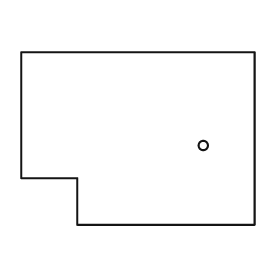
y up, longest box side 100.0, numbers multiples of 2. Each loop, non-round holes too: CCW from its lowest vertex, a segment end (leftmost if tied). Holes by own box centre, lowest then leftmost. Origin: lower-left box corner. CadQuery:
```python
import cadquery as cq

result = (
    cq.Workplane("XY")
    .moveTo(24.0, 0.0)
    .lineTo(100.0, 0.0)
    .lineTo(100.0, 74.0)
    .lineTo(0.0, 74.0)
    .lineTo(0.0, 20.0)
    .lineTo(24.0, 20.0)
    .close()
    .moveTo(78.0, 34.0)
    .circle(2.0)
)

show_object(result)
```